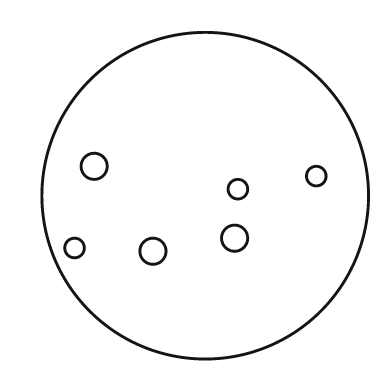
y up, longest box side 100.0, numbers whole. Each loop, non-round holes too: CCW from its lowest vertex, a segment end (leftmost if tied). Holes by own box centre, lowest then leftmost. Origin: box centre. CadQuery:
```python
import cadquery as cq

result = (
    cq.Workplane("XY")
    .moveTo(0.0, 0.0)
    .circle(50.0)
    .moveTo(-16.0, -17.0)
    .circle(4.0)
    .moveTo(-40.0, -16.0)
    .circle(3.0)
    .moveTo(9.0, -13.0)
    .circle(4.0)
    .moveTo(10.0, 2.0)
    .circle(3.0)
    .moveTo(34.0, 6.0)
    .circle(3.0)
    .moveTo(-34.0, 9.0)
    .circle(4.0)
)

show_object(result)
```